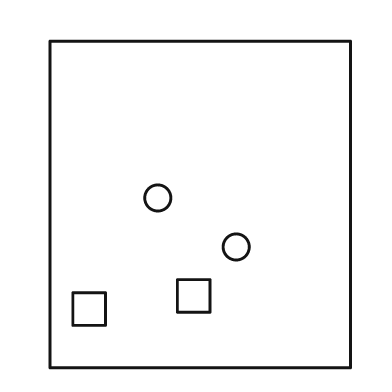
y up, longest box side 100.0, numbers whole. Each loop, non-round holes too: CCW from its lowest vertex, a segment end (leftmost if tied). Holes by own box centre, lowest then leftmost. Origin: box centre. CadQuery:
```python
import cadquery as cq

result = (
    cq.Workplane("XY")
    .moveTo(-46.0, -50.0)
    .lineTo(46.0, -50.0)
    .lineTo(46.0, 50.0)
    .lineTo(-46.0, 50.0)
    .close()
    .moveTo(-39.0, -37.0)
    .lineTo(-29.0, -37.0)
    .lineTo(-29.0, -27.0)
    .lineTo(-39.0, -27.0)
    .close()
    .moveTo(-7.0, -33.0)
    .lineTo(3.0, -33.0)
    .lineTo(3.0, -23.0)
    .lineTo(-7.0, -23.0)
    .close()
    .moveTo(11.0, -13.0)
    .circle(4.0)
    .moveTo(-13.0, 2.0)
    .circle(4.0)
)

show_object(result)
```